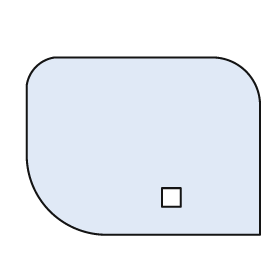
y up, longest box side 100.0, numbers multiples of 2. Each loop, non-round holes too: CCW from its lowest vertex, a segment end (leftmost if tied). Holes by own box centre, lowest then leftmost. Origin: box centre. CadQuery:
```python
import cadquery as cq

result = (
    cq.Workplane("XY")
    .moveTo(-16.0, -38.0)
    .lineTo(50.0, -38.0)
    .lineTo(50.0, 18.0)
    .threePointArc((44.0, 32.0), (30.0, 38.0))
    .lineTo(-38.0, 38.0)
    .threePointArc((-46.0, 34.0), (-50.0, 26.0))
    .lineTo(-50.0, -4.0)
    .threePointArc((-40.0, -28.0), (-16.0, -38.0))
    .close()
    .moveTo(8.0, -26.0)
    .lineTo(16.0, -26.0)
    .lineTo(16.0, -18.0)
    .lineTo(8.0, -18.0)
    .close()
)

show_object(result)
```